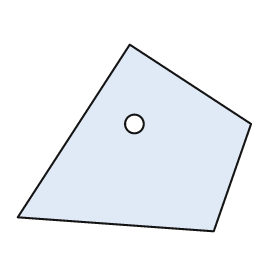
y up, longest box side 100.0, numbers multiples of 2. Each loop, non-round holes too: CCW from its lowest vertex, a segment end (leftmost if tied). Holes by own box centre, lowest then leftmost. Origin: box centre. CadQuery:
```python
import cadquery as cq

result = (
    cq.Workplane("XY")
    .moveTo(34.0, -40.0)
    .lineTo(50.0, 6.0)
    .lineTo(-2.0, 40.0)
    .lineTo(-50.0, -34.0)
    .close()
    .moveTo(0.0, 6.0)
    .circle(4.0)
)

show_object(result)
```